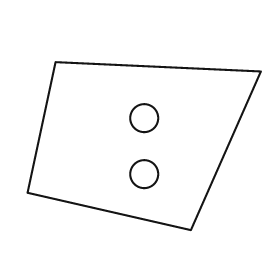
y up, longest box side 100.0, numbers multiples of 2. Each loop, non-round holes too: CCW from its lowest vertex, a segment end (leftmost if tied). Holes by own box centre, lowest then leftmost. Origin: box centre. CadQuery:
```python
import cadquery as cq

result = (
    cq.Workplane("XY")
    .moveTo(20.0, -36.0)
    .lineTo(50.0, 32.0)
    .lineTo(-38.0, 36.0)
    .lineTo(-50.0, -20.0)
    .close()
    .moveTo(0.0, -12.0)
    .circle(6.0)
    .moveTo(0.0, 12.0)
    .circle(6.0)
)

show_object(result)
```